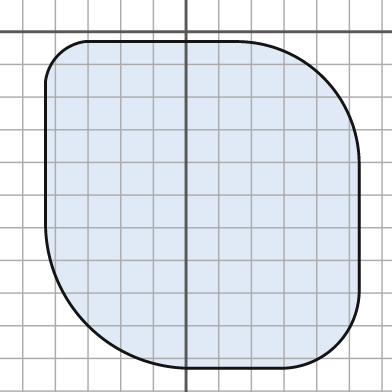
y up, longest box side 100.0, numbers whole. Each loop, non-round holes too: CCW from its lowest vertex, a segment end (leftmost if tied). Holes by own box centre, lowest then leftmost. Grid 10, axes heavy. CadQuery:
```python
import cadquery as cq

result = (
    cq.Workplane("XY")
    .moveTo(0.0, -103.0)
    .lineTo(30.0, -103.0)
    .threePointArc((46.0, -96.0), (53.0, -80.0))
    .lineTo(53.0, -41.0)
    .threePointArc((42.0, -14.0), (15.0, -3.0))
    .lineTo(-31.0, -3.0)
    .threePointArc((-39.0, -7.0), (-43.0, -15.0))
    .lineTo(-43.0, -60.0)
    .threePointArc((-30.0, -90.0), (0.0, -103.0))
    .close()
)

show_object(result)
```